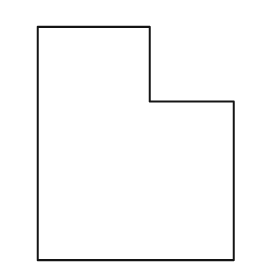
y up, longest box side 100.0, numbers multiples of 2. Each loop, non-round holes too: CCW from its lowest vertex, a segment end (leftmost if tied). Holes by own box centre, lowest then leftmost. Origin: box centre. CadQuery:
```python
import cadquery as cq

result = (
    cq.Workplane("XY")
    .moveTo(-42.0, -50.0)
    .lineTo(42.0, -50.0)
    .lineTo(42.0, 18.0)
    .lineTo(6.0, 18.0)
    .lineTo(6.0, 50.0)
    .lineTo(-42.0, 50.0)
    .close()
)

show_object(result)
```